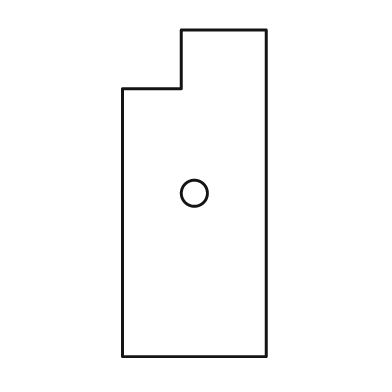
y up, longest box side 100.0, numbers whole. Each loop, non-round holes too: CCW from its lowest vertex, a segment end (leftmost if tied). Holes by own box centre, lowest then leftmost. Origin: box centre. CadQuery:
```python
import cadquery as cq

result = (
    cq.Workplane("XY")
    .moveTo(-22.0, -50.0)
    .lineTo(22.0, -50.0)
    .lineTo(22.0, 50.0)
    .lineTo(-4.0, 50.0)
    .lineTo(-4.0, 32.0)
    .lineTo(-22.0, 32.0)
    .close()
    .moveTo(0.0, 0.0)
    .circle(4.0)
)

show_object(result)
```